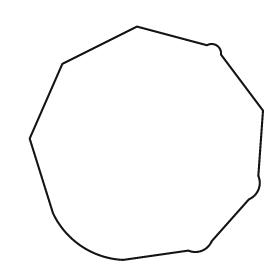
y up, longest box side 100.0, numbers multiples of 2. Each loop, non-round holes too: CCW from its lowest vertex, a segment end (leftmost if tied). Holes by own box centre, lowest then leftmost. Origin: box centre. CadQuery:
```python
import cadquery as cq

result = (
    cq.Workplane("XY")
    .moveTo(-10.0, -50.0)
    .lineTo(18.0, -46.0)
    .threePointArc((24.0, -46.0), (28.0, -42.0))
    .lineTo(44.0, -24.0)
    .threePointArc((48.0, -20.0), (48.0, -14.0))
    .lineTo(50.0, 14.0)
    .lineTo(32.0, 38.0)
    .threePointArc((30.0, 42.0), (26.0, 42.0))
    .lineTo(-4.0, 50.0)
    .lineTo(-36.0, 34.0)
    .lineTo(-50.0, 2.0)
    .lineTo(-40.0, -30.0)
    .threePointArc((-28.0, -44.0), (-10.0, -50.0))
    .close()
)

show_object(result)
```